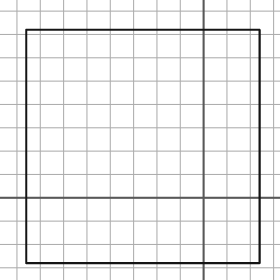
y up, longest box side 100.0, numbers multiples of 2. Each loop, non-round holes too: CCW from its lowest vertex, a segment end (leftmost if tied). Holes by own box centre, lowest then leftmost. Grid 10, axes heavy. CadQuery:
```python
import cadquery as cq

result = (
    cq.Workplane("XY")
    .moveTo(-76.0, -28.0)
    .lineTo(24.0, -28.0)
    .lineTo(24.0, 72.0)
    .lineTo(-76.0, 72.0)
    .close()
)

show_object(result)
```